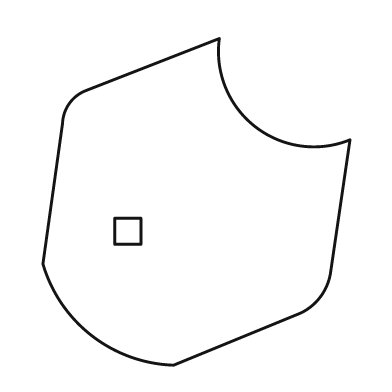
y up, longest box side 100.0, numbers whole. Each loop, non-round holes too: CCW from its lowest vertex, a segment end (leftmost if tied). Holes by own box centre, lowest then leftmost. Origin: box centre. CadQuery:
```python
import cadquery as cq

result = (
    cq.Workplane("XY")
    .moveTo(-7.0, -50.0)
    .lineTo(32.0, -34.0)
    .threePointArc((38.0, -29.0), (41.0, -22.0))
    .lineTo(47.0, 19.0)
    .threePointArc((18.0, 23.0), (7.0, 50.0))
    .lineTo(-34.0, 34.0)
    .threePointArc((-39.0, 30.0), (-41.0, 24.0))
    .lineTo(-47.0, -19.0)
    .threePointArc((-32.0, -41.0), (-7.0, -50.0))
    .close()
    .moveTo(-25.0, -13.0)
    .lineTo(-17.0, -13.0)
    .lineTo(-17.0, -5.0)
    .lineTo(-25.0, -5.0)
    .close()
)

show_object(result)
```